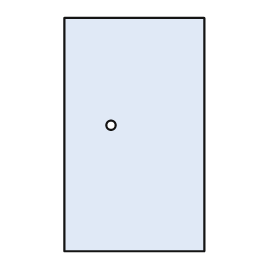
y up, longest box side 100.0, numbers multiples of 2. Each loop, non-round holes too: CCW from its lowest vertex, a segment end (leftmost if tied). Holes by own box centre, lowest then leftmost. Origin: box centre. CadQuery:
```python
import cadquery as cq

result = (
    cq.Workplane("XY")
    .moveTo(-30.0, -50.0)
    .lineTo(30.0, -50.0)
    .lineTo(30.0, 50.0)
    .lineTo(-30.0, 50.0)
    .close()
    .moveTo(-10.0, 4.0)
    .circle(2.0)
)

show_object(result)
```